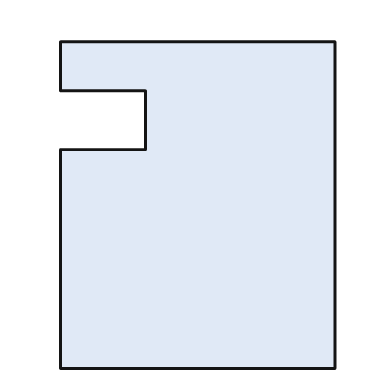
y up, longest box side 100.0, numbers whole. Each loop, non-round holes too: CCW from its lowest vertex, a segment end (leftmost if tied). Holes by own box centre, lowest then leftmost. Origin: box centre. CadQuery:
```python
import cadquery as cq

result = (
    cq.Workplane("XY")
    .moveTo(-42.0, -50.0)
    .lineTo(42.0, -50.0)
    .lineTo(42.0, 50.0)
    .lineTo(-42.0, 50.0)
    .lineTo(-42.0, 35.0)
    .lineTo(-16.0, 35.0)
    .lineTo(-16.0, 17.0)
    .lineTo(-42.0, 17.0)
    .close()
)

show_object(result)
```